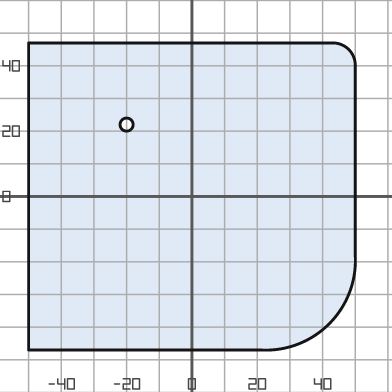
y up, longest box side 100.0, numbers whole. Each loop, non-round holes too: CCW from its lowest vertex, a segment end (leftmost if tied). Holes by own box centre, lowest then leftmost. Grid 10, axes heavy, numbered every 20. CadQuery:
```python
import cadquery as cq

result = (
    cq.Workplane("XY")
    .moveTo(-50.0, -47.0)
    .lineTo(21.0, -47.0)
    .threePointArc((42.0, -39.0), (50.0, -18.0))
    .lineTo(50.0, 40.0)
    .threePointArc((48.0, 45.0), (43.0, 47.0))
    .lineTo(-50.0, 47.0)
    .close()
    .moveTo(-20.0, 22.0)
    .circle(2.0)
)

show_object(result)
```